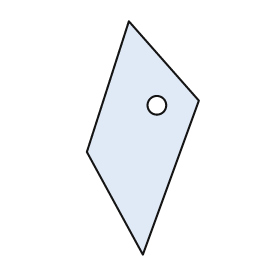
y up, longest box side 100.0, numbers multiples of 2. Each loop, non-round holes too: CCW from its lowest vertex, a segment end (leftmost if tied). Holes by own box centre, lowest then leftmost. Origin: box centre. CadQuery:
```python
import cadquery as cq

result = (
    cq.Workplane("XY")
    .moveTo(0.0, -50.0)
    .lineTo(24.0, 16.0)
    .lineTo(-6.0, 50.0)
    .lineTo(-24.0, -6.0)
    .close()
    .moveTo(6.0, 14.0)
    .circle(4.0)
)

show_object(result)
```